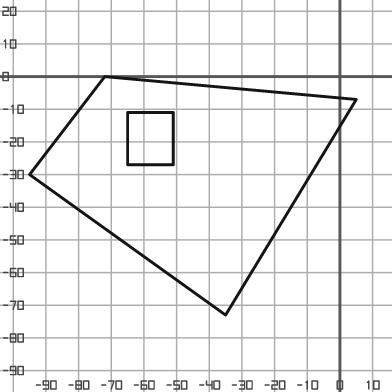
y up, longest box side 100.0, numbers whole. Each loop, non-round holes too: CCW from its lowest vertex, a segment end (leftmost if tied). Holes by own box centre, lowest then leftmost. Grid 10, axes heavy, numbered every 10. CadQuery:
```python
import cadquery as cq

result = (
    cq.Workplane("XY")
    .moveTo(-35.0, -73.0)
    .lineTo(5.0, -7.0)
    .lineTo(-72.0, 0.0)
    .lineTo(-95.0, -30.0)
    .close()
    .moveTo(-65.0, -27.0)
    .lineTo(-51.0, -27.0)
    .lineTo(-51.0, -11.0)
    .lineTo(-65.0, -11.0)
    .close()
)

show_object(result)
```